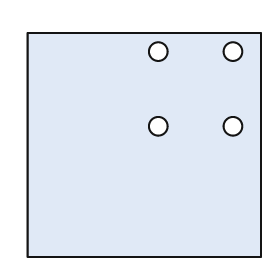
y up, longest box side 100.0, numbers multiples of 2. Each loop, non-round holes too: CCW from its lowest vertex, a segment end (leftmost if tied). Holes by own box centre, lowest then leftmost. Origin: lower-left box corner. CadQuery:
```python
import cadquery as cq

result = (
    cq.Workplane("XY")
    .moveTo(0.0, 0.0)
    .lineTo(100.0, 0.0)
    .lineTo(100.0, 96.0)
    .lineTo(0.0, 96.0)
    .close()
    .moveTo(56.0, 56.0)
    .circle(4.0)
    .moveTo(88.0, 56.0)
    .circle(4.0)
    .moveTo(56.0, 88.0)
    .circle(4.0)
    .moveTo(88.0, 88.0)
    .circle(4.0)
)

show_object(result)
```